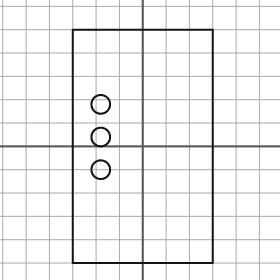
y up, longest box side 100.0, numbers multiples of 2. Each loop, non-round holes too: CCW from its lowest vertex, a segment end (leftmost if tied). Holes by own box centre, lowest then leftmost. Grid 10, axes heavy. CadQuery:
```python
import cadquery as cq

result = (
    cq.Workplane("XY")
    .moveTo(-30.0, -50.0)
    .lineTo(30.0, -50.0)
    .lineTo(30.0, 50.0)
    .lineTo(-30.0, 50.0)
    .close()
    .moveTo(-18.0, -10.0)
    .circle(4.0)
    .moveTo(-18.0, 4.0)
    .circle(4.0)
    .moveTo(-18.0, 18.0)
    .circle(4.0)
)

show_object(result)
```